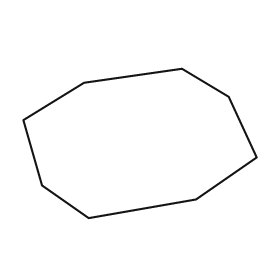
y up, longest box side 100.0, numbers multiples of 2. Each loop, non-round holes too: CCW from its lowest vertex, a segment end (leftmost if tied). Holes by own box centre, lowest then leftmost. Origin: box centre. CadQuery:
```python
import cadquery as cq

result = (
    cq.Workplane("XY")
    .moveTo(-22.0, -32.0)
    .lineTo(24.0, -24.0)
    .lineTo(50.0, -6.0)
    .lineTo(38.0, 20.0)
    .lineTo(18.0, 32.0)
    .lineTo(-24.0, 26.0)
    .lineTo(-50.0, 10.0)
    .lineTo(-42.0, -18.0)
    .close()
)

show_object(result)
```